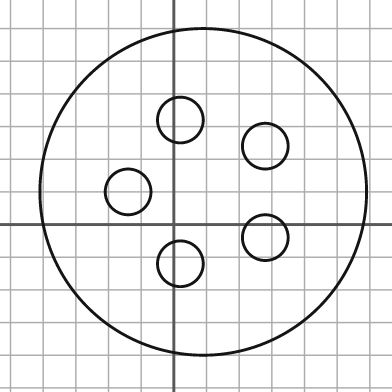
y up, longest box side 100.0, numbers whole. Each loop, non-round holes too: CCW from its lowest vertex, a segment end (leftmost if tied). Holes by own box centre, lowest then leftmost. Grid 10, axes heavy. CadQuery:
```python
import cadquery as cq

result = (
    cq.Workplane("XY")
    .moveTo(9.0, 10.0)
    .circle(50.0)
    .moveTo(2.0, -12.0)
    .circle(7.0)
    .moveTo(28.0, -4.0)
    .circle(7.0)
    .moveTo(-14.0, 10.0)
    .circle(7.0)
    .moveTo(28.0, 24.0)
    .circle(7.0)
    .moveTo(2.0, 32.0)
    .circle(7.0)
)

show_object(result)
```